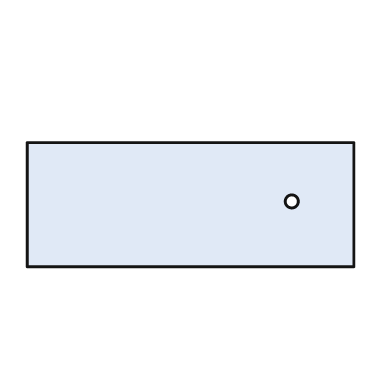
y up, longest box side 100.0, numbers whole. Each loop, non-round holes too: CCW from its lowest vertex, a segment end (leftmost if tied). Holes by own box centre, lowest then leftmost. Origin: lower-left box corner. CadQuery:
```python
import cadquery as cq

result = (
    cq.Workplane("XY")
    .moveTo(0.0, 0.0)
    .lineTo(100.0, 0.0)
    .lineTo(100.0, 38.0)
    .lineTo(0.0, 38.0)
    .close()
    .moveTo(81.0, 20.0)
    .circle(2.0)
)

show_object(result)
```